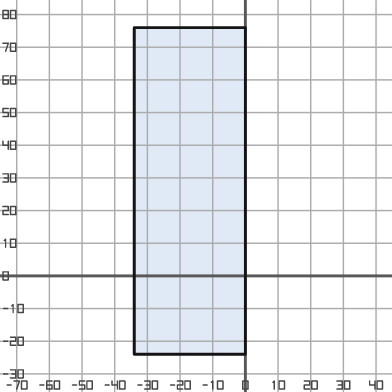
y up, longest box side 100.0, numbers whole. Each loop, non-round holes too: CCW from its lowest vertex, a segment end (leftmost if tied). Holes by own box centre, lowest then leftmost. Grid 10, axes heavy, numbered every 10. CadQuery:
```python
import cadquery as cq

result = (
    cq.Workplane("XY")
    .moveTo(-34.0, -24.0)
    .lineTo(0.0, -24.0)
    .lineTo(0.0, 76.0)
    .lineTo(-34.0, 76.0)
    .close()
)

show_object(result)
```